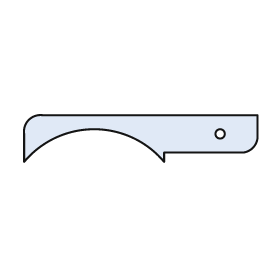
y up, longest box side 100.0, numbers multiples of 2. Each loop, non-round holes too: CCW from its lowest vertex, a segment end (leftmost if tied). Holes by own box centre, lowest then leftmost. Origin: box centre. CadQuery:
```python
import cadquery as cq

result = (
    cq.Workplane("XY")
    .moveTo(-50.0, -10.0)
    .threePointArc((-20.0, 4.0), (10.0, -10.0))
    .lineTo(10.0, -6.0)
    .lineTo(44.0, -6.0)
    .threePointArc((48.0, -4.0), (50.0, 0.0))
    .lineTo(50.0, 10.0)
    .lineTo(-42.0, 10.0)
    .threePointArc((-48.0, 8.0), (-50.0, 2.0))
    .close()
    .moveTo(34.0, 2.0)
    .circle(2.0)
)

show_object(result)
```